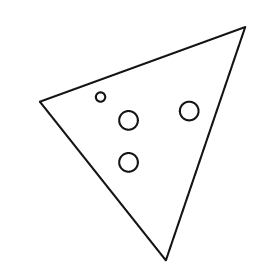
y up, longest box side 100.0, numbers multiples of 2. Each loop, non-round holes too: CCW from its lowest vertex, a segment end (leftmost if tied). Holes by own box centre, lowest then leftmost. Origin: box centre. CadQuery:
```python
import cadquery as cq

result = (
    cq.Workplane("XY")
    .moveTo(10.0, -50.0)
    .lineTo(44.0, 50.0)
    .lineTo(-44.0, 18.0)
    .close()
    .moveTo(-6.0, -8.0)
    .circle(4.0)
    .moveTo(-6.0, 10.0)
    .circle(4.0)
    .moveTo(20.0, 14.0)
    .circle(4.0)
    .moveTo(-18.0, 20.0)
    .circle(2.0)
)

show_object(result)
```